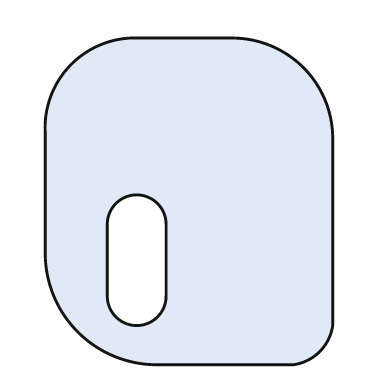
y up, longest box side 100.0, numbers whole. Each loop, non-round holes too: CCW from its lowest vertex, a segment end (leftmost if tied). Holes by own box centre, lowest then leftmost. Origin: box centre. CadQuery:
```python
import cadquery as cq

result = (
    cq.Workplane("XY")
    .moveTo(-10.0, -50.0)
    .lineTo(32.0, -50.0)
    .threePointArc((40.0, -46.0), (44.0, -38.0))
    .lineTo(44.0, 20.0)
    .threePointArc((35.0, 41.0), (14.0, 50.0))
    .lineTo(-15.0, 50.0)
    .threePointArc((-36.0, 42.0), (-44.0, 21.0))
    .lineTo(-44.0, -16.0)
    .threePointArc((-34.0, -40.0), (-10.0, -50.0))
    .close()
    .moveTo(-25.0, -29.0)
    .threePointArc((-16.0, -38.0), (-7.0, -29.0))
    .lineTo(-7.0, -7.0)
    .threePointArc((-16.0, 2.0), (-25.0, -7.0))
    .close()
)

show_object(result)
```